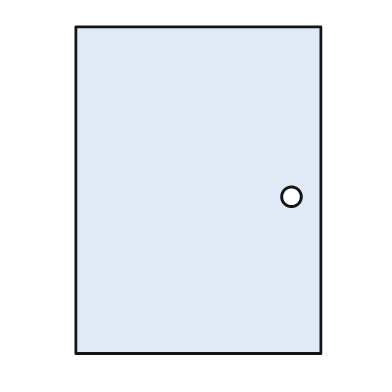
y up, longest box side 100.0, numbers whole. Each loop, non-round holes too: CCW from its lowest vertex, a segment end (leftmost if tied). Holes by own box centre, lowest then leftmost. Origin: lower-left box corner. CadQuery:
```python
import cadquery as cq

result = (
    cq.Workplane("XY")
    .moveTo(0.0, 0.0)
    .lineTo(75.0, 0.0)
    .lineTo(75.0, 100.0)
    .lineTo(0.0, 100.0)
    .close()
    .moveTo(66.0, 48.0)
    .circle(3.0)
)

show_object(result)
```